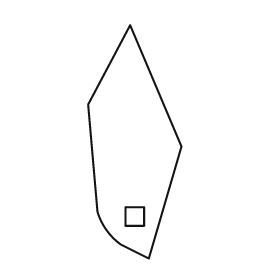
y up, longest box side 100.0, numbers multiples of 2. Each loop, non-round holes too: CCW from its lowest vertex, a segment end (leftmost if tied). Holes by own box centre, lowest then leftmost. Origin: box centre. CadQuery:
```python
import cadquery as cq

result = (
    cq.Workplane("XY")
    .moveTo(6.0, -50.0)
    .lineTo(20.0, -2.0)
    .lineTo(-2.0, 50.0)
    .lineTo(-20.0, 16.0)
    .lineTo(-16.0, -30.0)
    .threePointArc((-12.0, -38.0), (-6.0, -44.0))
    .close()
    .moveTo(-4.0, -36.0)
    .lineTo(4.0, -36.0)
    .lineTo(4.0, -28.0)
    .lineTo(-4.0, -28.0)
    .close()
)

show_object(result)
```